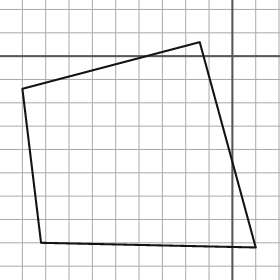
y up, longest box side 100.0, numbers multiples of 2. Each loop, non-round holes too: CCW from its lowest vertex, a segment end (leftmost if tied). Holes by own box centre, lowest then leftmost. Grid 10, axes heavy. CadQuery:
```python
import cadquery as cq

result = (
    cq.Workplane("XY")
    .moveTo(10.0, -82.0)
    .lineTo(-14.0, 6.0)
    .lineTo(-90.0, -14.0)
    .lineTo(-82.0, -80.0)
    .close()
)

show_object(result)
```